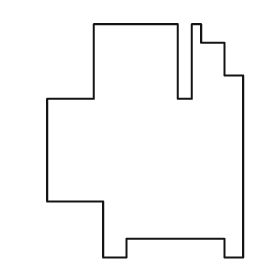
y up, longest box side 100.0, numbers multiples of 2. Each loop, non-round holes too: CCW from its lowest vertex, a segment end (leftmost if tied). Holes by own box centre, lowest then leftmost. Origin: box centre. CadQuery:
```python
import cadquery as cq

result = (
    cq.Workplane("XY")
    .moveTo(-18.0, -50.0)
    .lineTo(-8.0, -50.0)
    .lineTo(-8.0, -42.0)
    .lineTo(34.0, -42.0)
    .lineTo(34.0, -50.0)
    .lineTo(42.0, -50.0)
    .lineTo(42.0, 28.0)
    .lineTo(34.0, 28.0)
    .lineTo(34.0, 42.0)
    .lineTo(24.0, 42.0)
    .lineTo(24.0, 50.0)
    .lineTo(20.0, 50.0)
    .lineTo(20.0, 18.0)
    .lineTo(14.0, 18.0)
    .lineTo(14.0, 50.0)
    .lineTo(-22.0, 50.0)
    .lineTo(-22.0, 18.0)
    .lineTo(-42.0, 18.0)
    .lineTo(-42.0, -26.0)
    .lineTo(-18.0, -26.0)
    .close()
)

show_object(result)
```